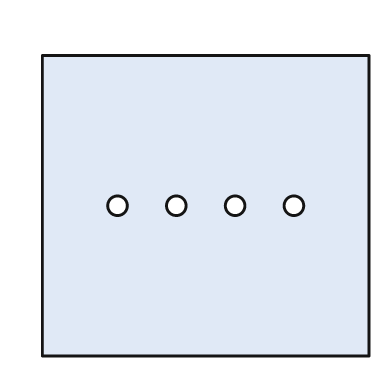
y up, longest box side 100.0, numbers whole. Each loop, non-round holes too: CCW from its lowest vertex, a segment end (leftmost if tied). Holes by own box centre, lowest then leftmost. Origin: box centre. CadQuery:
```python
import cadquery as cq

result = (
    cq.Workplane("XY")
    .moveTo(-50.0, -46.0)
    .lineTo(50.0, -46.0)
    .lineTo(50.0, 46.0)
    .lineTo(-50.0, 46.0)
    .close()
    .moveTo(-27.0, 0.0)
    .circle(3.0)
    .moveTo(-9.0, 0.0)
    .circle(3.0)
    .moveTo(9.0, 0.0)
    .circle(3.0)
    .moveTo(27.0, 0.0)
    .circle(3.0)
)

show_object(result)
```